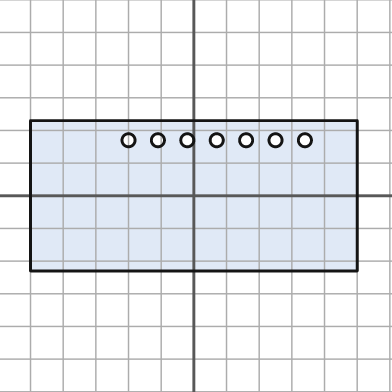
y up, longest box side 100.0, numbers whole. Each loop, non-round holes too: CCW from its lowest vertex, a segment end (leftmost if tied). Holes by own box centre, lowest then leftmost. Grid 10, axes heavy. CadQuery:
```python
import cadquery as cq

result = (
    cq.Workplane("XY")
    .moveTo(-50.0, -23.0)
    .lineTo(50.0, -23.0)
    .lineTo(50.0, 23.0)
    .lineTo(-50.0, 23.0)
    .close()
    .moveTo(-20.0, 17.0)
    .circle(2.0)
    .moveTo(-11.0, 17.0)
    .circle(2.0)
    .moveTo(-2.0, 17.0)
    .circle(2.0)
    .moveTo(7.0, 17.0)
    .circle(2.0)
    .moveTo(16.0, 17.0)
    .circle(2.0)
    .moveTo(25.0, 17.0)
    .circle(2.0)
    .moveTo(34.0, 17.0)
    .circle(2.0)
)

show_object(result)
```